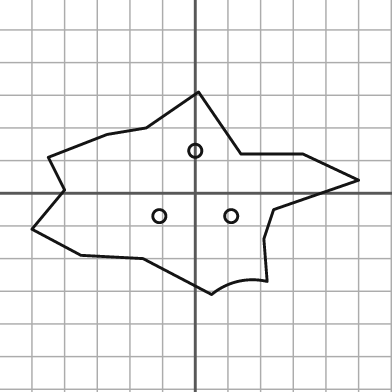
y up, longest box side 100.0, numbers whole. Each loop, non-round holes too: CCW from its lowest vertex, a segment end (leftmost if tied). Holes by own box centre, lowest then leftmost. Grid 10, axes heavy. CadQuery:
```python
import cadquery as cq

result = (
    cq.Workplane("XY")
    .moveTo(5.0, -31.0)
    .threePointArc((13.0, -27.0), (22.0, -27.0))
    .lineTo(21.0, -14.0)
    .lineTo(24.0, -5.0)
    .lineTo(50.0, 4.0)
    .lineTo(33.0, 12.0)
    .lineTo(14.0, 12.0)
    .lineTo(1.0, 31.0)
    .lineTo(-15.0, 20.0)
    .lineTo(-27.0, 18.0)
    .lineTo(-45.0, 11.0)
    .lineTo(-40.0, 1.0)
    .lineTo(-50.0, -11.0)
    .lineTo(-35.0, -19.0)
    .lineTo(-16.0, -20.0)
    .close()
    .moveTo(-11.0, -7.0)
    .circle(2.0)
    .moveTo(11.0, -7.0)
    .circle(2.0)
    .moveTo(0.0, 13.0)
    .circle(2.0)
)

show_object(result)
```